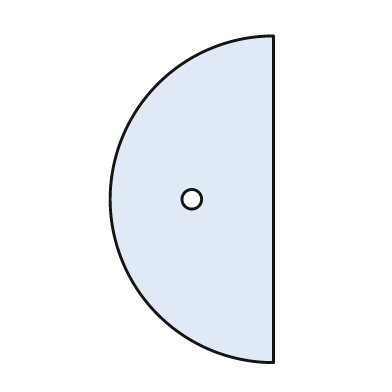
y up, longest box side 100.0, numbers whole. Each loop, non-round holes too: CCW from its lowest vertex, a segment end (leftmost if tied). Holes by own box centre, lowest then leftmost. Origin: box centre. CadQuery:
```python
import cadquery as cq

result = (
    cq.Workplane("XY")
    .moveTo(25.0, -50.0)
    .lineTo(25.0, 50.0)
    .threePointArc((-25.0, 0.0), (25.0, -50.0))
    .close()
    .moveTo(0.0, 0.0)
    .circle(3.0)
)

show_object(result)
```